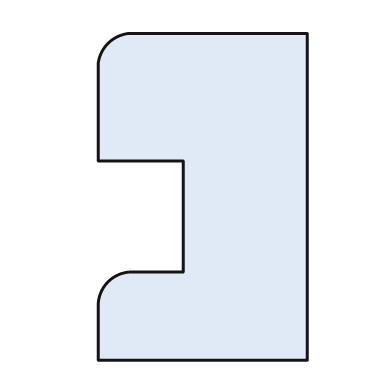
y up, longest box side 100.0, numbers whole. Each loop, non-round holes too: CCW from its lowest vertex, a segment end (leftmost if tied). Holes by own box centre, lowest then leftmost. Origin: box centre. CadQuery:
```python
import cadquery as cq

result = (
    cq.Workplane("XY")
    .moveTo(-32.0, -50.0)
    .lineTo(32.0, -50.0)
    .lineTo(32.0, 50.0)
    .lineTo(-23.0, 50.0)
    .threePointArc((-29.0, 47.0), (-32.0, 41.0))
    .lineTo(-32.0, 11.0)
    .lineTo(-6.0, 11.0)
    .lineTo(-6.0, -23.0)
    .lineTo(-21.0, -23.0)
    .threePointArc((-29.0, -26.0), (-32.0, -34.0))
    .close()
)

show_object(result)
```